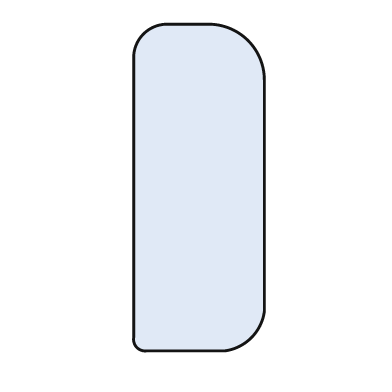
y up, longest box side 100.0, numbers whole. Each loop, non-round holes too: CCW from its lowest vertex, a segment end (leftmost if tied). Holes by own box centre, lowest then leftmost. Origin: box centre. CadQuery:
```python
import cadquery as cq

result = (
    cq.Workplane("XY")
    .moveTo(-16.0, -50.0)
    .lineTo(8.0, -50.0)
    .threePointArc((16.0, -46.0), (20.0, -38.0))
    .lineTo(20.0, 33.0)
    .threePointArc((15.0, 45.0), (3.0, 50.0))
    .lineTo(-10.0, 50.0)
    .threePointArc((-17.0, 47.0), (-20.0, 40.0))
    .lineTo(-20.0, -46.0)
    .threePointArc((-19.0, -49.0), (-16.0, -50.0))
    .close()
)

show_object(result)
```